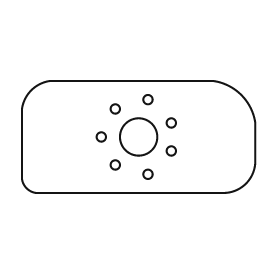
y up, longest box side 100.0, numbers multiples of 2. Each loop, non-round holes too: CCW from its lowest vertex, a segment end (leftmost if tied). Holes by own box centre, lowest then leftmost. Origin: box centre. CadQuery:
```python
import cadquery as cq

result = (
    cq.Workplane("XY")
    .moveTo(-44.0, -24.0)
    .lineTo(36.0, -24.0)
    .threePointArc((46.0, -20.0), (50.0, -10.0))
    .lineTo(50.0, 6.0)
    .threePointArc((44.0, 18.0), (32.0, 24.0))
    .lineTo(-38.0, 24.0)
    .threePointArc((-46.0, 20.0), (-50.0, 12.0))
    .lineTo(-50.0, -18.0)
    .threePointArc((-48.0, -22.0), (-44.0, -24.0))
    .close()
    .moveTo(4.0, -16.0)
    .circle(2.0)
    .moveTo(-10.0, -12.0)
    .circle(2.0)
    .moveTo(14.0, -6.0)
    .circle(2.0)
    .moveTo(-16.0, 0.0)
    .circle(2.0)
    .moveTo(0.0, 0.0)
    .circle(8.0)
    .moveTo(14.0, 6.0)
    .circle(2.0)
    .moveTo(-10.0, 12.0)
    .circle(2.0)
    .moveTo(4.0, 16.0)
    .circle(2.0)
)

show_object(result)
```